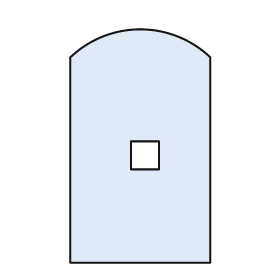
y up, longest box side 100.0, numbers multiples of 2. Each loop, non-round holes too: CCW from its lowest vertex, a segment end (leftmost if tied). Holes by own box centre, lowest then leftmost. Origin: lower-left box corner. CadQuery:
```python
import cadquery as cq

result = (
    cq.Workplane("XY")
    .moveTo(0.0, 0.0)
    .lineTo(60.0, 0.0)
    .lineTo(60.0, 88.0)
    .threePointArc((30.0, 100.0), (0.0, 88.0))
    .close()
    .moveTo(26.0, 40.0)
    .lineTo(38.0, 40.0)
    .lineTo(38.0, 52.0)
    .lineTo(26.0, 52.0)
    .close()
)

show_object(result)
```